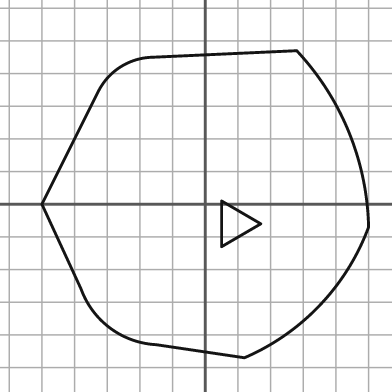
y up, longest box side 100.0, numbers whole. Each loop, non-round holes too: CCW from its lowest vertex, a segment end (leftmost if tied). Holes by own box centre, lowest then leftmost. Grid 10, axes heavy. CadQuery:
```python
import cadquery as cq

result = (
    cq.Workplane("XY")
    .moveTo(12.0, -47.0)
    .threePointArc((35.0, -31.0), (50.0, -7.0))
    .threePointArc((44.0, 22.0), (28.0, 47.0))
    .lineTo(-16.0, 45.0)
    .threePointArc((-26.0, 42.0), (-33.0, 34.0))
    .lineTo(-50.0, 0.0)
    .lineTo(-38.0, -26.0)
    .threePointArc((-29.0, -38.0), (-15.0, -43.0))
    .close()
    .moveTo(5.0, -13.0)
    .lineTo(17.0, -6.0)
    .lineTo(5.0, 1.0)
    .close()
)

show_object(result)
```